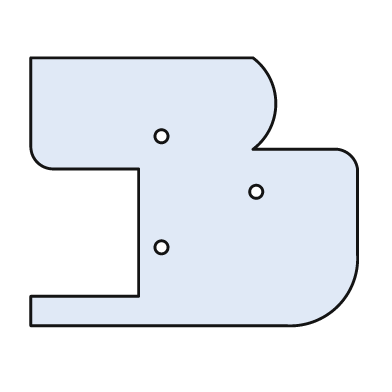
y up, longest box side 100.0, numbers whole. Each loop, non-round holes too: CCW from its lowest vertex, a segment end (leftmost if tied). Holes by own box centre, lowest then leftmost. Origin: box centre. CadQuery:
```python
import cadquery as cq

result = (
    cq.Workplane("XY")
    .moveTo(-50.0, -41.0)
    .lineTo(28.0, -41.0)
    .threePointArc((44.0, -35.0), (50.0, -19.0))
    .lineTo(50.0, 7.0)
    .threePointArc((48.0, 11.0), (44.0, 13.0))
    .lineTo(18.0, 13.0)
    .threePointArc((25.0, 27.0), (18.0, 41.0))
    .lineTo(-50.0, 41.0)
    .lineTo(-50.0, 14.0)
    .threePointArc((-48.0, 9.0), (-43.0, 7.0))
    .lineTo(-17.0, 7.0)
    .lineTo(-17.0, -32.0)
    .lineTo(-50.0, -32.0)
    .close()
    .moveTo(-10.0, -17.0)
    .circle(2.0)
    .moveTo(19.0, 0.0)
    .circle(2.0)
    .moveTo(-10.0, 17.0)
    .circle(2.0)
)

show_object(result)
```